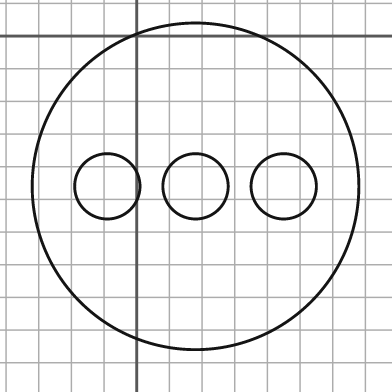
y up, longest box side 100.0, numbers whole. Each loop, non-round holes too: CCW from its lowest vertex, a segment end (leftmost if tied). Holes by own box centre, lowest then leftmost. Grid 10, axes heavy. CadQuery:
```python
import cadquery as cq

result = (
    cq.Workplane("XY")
    .moveTo(18.0, -46.0)
    .circle(50.0)
    .moveTo(-9.0, -46.0)
    .circle(10.0)
    .moveTo(18.0, -46.0)
    .circle(10.0)
    .moveTo(45.0, -46.0)
    .circle(10.0)
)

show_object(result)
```